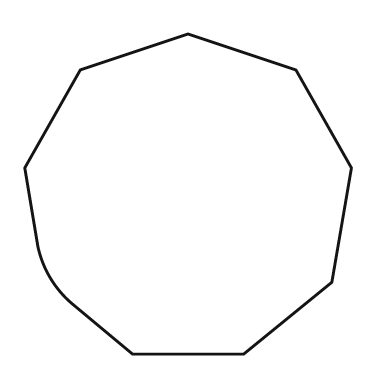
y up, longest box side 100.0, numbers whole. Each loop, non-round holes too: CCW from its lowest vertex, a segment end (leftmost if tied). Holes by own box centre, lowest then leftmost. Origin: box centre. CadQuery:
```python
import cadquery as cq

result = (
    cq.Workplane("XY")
    .moveTo(-17.0, -49.0)
    .lineTo(17.0, -49.0)
    .lineTo(44.0, -27.0)
    .lineTo(50.0, 8.0)
    .lineTo(33.0, 38.0)
    .lineTo(0.0, 49.0)
    .lineTo(-33.0, 38.0)
    .lineTo(-50.0, 8.0)
    .lineTo(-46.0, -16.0)
    .threePointArc((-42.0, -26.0), (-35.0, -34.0))
    .close()
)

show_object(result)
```